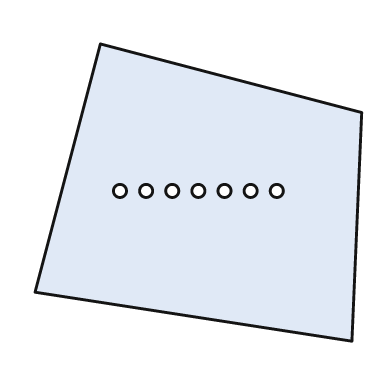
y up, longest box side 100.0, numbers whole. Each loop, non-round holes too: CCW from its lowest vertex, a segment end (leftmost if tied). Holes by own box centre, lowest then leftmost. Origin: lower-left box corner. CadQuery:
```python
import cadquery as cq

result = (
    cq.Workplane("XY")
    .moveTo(97.0, 0.0)
    .lineTo(100.0, 70.0)
    .lineTo(20.0, 91.0)
    .lineTo(0.0, 15.0)
    .close()
    .moveTo(26.0, 46.0)
    .circle(2.0)
    .moveTo(34.0, 46.0)
    .circle(2.0)
    .moveTo(42.0, 46.0)
    .circle(2.0)
    .moveTo(50.0, 46.0)
    .circle(2.0)
    .moveTo(58.0, 46.0)
    .circle(2.0)
    .moveTo(66.0, 46.0)
    .circle(2.0)
    .moveTo(74.0, 46.0)
    .circle(2.0)
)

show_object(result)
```